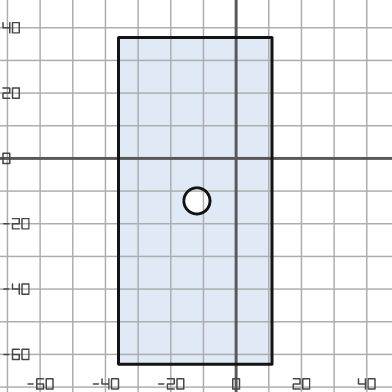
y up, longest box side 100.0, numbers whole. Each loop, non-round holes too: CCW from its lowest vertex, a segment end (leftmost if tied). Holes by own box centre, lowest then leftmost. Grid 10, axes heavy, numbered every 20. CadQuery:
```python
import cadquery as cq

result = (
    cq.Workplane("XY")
    .moveTo(-36.0, -63.0)
    .lineTo(11.0, -63.0)
    .lineTo(11.0, 37.0)
    .lineTo(-36.0, 37.0)
    .close()
    .moveTo(-12.0, -13.0)
    .circle(4.0)
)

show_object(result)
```